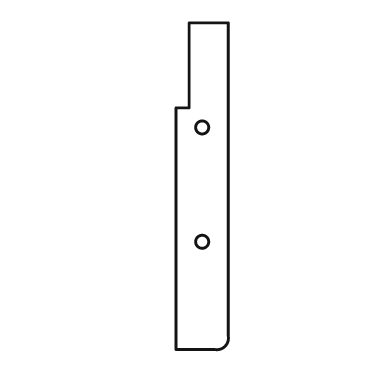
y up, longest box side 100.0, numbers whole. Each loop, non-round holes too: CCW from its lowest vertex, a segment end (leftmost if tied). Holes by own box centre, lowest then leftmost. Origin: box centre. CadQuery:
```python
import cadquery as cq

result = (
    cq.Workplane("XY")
    .moveTo(-8.0, -50.0)
    .lineTo(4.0, -50.0)
    .threePointArc((7.0, -49.0), (8.0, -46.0))
    .lineTo(8.0, 50.0)
    .lineTo(-4.0, 50.0)
    .lineTo(-4.0, 24.0)
    .lineTo(-8.0, 24.0)
    .close()
    .moveTo(0.0, -17.0)
    .circle(2.0)
    .moveTo(0.0, 18.0)
    .circle(2.0)
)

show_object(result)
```